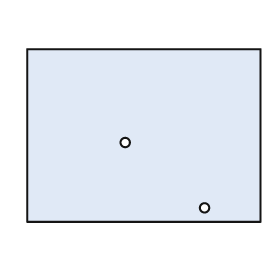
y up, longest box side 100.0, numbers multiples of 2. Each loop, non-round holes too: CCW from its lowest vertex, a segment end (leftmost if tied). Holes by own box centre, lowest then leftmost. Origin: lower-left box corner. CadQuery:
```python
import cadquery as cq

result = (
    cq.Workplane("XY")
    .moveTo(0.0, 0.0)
    .lineTo(100.0, 0.0)
    .lineTo(100.0, 74.0)
    .lineTo(0.0, 74.0)
    .close()
    .moveTo(76.0, 6.0)
    .circle(2.0)
    .moveTo(42.0, 34.0)
    .circle(2.0)
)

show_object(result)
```